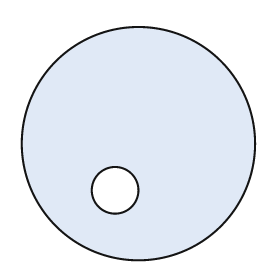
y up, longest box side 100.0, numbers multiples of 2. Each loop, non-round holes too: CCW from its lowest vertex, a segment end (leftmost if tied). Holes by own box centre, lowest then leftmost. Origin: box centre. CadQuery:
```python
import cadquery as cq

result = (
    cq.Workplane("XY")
    .moveTo(0.0, 0.0)
    .circle(50.0)
    .moveTo(-10.0, -20.0)
    .circle(10.0)
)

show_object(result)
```